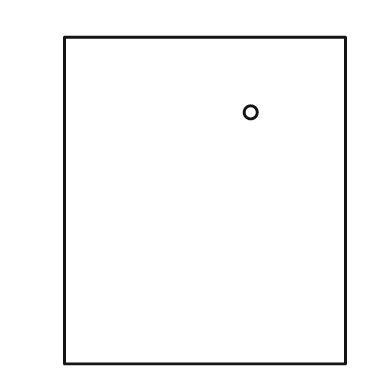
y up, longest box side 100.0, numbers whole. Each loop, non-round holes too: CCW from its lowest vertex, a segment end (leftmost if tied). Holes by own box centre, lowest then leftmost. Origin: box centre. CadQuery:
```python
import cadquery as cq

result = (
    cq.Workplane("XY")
    .moveTo(-43.0, -50.0)
    .lineTo(43.0, -50.0)
    .lineTo(43.0, 50.0)
    .lineTo(-43.0, 50.0)
    .close()
    .moveTo(14.0, 27.0)
    .circle(2.0)
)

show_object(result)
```